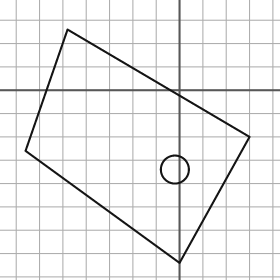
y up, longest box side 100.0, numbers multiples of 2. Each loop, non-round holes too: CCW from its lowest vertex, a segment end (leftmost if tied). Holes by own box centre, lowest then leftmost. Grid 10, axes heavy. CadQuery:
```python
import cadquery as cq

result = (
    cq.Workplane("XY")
    .moveTo(0.0, -74.0)
    .lineTo(30.0, -20.0)
    .lineTo(-48.0, 26.0)
    .lineTo(-66.0, -26.0)
    .close()
    .moveTo(-2.0, -34.0)
    .circle(6.0)
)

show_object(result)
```